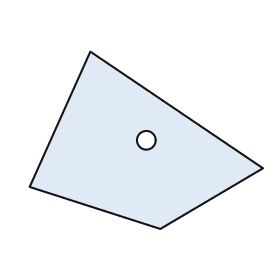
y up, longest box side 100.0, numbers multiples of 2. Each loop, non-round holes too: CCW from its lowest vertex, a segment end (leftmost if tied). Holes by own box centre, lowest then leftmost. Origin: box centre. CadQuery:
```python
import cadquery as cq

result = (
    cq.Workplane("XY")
    .moveTo(6.0, -38.0)
    .lineTo(50.0, -12.0)
    .lineTo(-24.0, 38.0)
    .lineTo(-50.0, -20.0)
    .close()
    .moveTo(0.0, 0.0)
    .circle(4.0)
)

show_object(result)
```